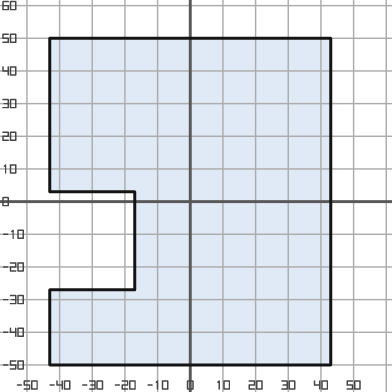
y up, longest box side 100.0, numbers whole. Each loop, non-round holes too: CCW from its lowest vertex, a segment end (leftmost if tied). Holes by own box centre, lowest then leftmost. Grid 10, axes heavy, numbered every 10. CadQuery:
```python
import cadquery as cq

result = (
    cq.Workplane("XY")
    .moveTo(-43.0, -50.0)
    .lineTo(43.0, -50.0)
    .lineTo(43.0, 50.0)
    .lineTo(-43.0, 50.0)
    .lineTo(-43.0, 3.0)
    .lineTo(-17.0, 3.0)
    .lineTo(-17.0, -27.0)
    .lineTo(-43.0, -27.0)
    .close()
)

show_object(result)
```